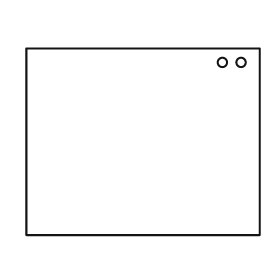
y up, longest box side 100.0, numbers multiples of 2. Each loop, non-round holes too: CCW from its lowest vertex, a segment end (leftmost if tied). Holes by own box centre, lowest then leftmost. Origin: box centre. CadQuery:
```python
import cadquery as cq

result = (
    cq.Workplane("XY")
    .moveTo(-50.0, -40.0)
    .lineTo(50.0, -40.0)
    .lineTo(50.0, 40.0)
    .lineTo(-50.0, 40.0)
    .close()
    .moveTo(34.0, 34.0)
    .circle(2.0)
    .moveTo(42.0, 34.0)
    .circle(2.0)
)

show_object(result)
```